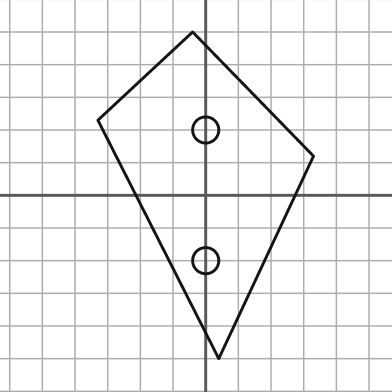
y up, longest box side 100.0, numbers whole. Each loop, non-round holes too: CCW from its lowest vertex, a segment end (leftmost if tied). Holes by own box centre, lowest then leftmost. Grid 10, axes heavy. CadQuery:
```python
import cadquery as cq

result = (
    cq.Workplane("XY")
    .moveTo(4.0, -50.0)
    .lineTo(33.0, 12.0)
    .lineTo(-4.0, 50.0)
    .lineTo(-33.0, 23.0)
    .close()
    .moveTo(0.0, -20.0)
    .circle(4.0)
    .moveTo(0.0, 20.0)
    .circle(4.0)
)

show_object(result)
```